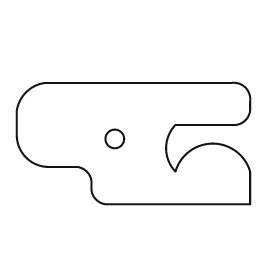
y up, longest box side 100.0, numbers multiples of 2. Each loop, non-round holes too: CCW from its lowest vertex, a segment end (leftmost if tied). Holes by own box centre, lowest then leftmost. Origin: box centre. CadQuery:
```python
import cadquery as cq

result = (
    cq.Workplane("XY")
    .moveTo(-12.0, -26.0)
    .lineTo(50.0, -26.0)
    .lineTo(50.0, -12.0)
    .threePointArc((34.0, 0.0), (18.0, -12.0))
    .threePointArc((14.0, -2.0), (18.0, 8.0))
    .lineTo(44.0, 8.0)
    .threePointArc((48.0, 10.0), (50.0, 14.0))
    .lineTo(50.0, 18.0)
    .threePointArc((48.0, 24.0), (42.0, 26.0))
    .lineTo(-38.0, 26.0)
    .threePointArc((-46.0, 22.0), (-50.0, 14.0))
    .lineTo(-50.0, 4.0)
    .threePointArc((-46.0, -6.0), (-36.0, -10.0))
    .lineTo(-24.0, -10.0)
    .threePointArc((-20.0, -12.0), (-18.0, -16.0))
    .lineTo(-18.0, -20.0)
    .threePointArc((-16.0, -24.0), (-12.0, -26.0))
    .close()
    .moveTo(-8.0, 2.0)
    .circle(4.0)
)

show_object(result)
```